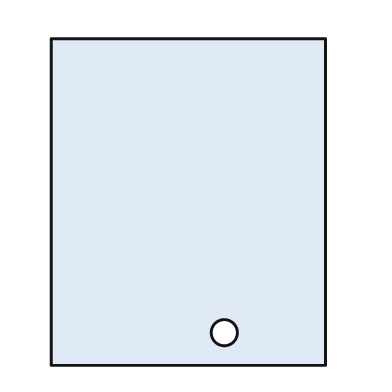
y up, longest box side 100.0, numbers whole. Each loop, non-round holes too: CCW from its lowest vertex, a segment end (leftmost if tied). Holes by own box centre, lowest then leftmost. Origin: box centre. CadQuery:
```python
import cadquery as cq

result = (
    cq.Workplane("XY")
    .moveTo(-42.0, -50.0)
    .lineTo(42.0, -50.0)
    .lineTo(42.0, 50.0)
    .lineTo(-42.0, 50.0)
    .close()
    .moveTo(11.0, -40.0)
    .circle(4.0)
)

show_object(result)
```